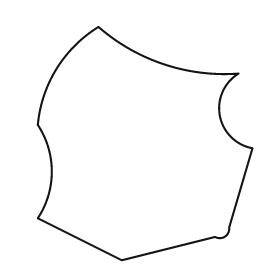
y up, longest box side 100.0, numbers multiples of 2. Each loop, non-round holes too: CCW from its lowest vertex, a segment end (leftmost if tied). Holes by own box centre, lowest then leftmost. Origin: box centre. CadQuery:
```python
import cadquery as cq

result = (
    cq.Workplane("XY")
    .moveTo(-10.0, -50.0)
    .lineTo(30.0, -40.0)
    .threePointArc((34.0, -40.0), (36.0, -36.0))
    .lineTo(46.0, -2.0)
    .threePointArc((32.0, 12.0), (40.0, 30.0))
    .threePointArc((8.0, 34.0), (-20.0, 50.0))
    .threePointArc((-38.0, 32.0), (-46.0, 8.0))
    .threePointArc((-40.0, -12.0), (-46.0, -32.0))
    .close()
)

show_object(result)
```